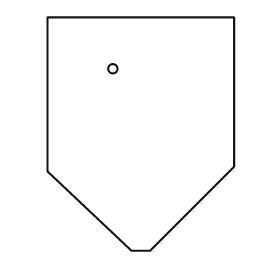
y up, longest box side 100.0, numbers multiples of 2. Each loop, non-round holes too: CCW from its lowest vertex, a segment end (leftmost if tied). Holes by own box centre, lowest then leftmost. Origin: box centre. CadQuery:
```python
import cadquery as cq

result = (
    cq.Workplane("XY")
    .moveTo(-4.0, -50.0)
    .lineTo(4.0, -50.0)
    .lineTo(40.0, -14.0)
    .lineTo(40.0, 50.0)
    .lineTo(-40.0, 50.0)
    .lineTo(-40.0, -16.0)
    .close()
    .moveTo(-12.0, 28.0)
    .circle(2.0)
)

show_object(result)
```